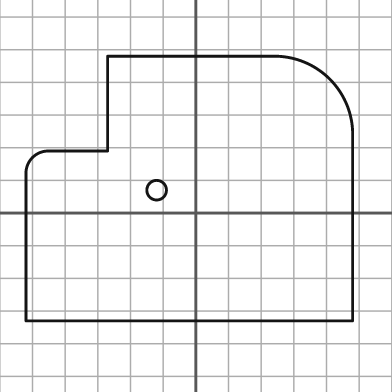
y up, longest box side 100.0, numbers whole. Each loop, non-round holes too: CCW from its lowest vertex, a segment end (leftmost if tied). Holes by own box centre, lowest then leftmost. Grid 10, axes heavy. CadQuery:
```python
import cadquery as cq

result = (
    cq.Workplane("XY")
    .moveTo(-52.0, -33.0)
    .lineTo(48.0, -33.0)
    .lineTo(48.0, 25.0)
    .threePointArc((41.0, 41.0), (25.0, 48.0))
    .lineTo(-27.0, 48.0)
    .lineTo(-27.0, 19.0)
    .lineTo(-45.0, 19.0)
    .threePointArc((-50.0, 17.0), (-52.0, 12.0))
    .close()
    .moveTo(-12.0, 7.0)
    .circle(3.0)
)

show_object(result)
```